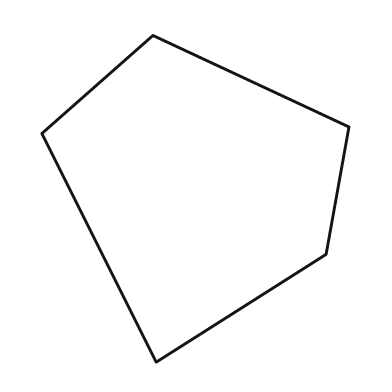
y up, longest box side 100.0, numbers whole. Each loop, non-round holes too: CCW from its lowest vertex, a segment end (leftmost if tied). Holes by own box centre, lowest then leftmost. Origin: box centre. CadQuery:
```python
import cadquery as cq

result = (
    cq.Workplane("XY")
    .moveTo(-12.0, -50.0)
    .lineTo(40.0, -17.0)
    .lineTo(47.0, 22.0)
    .lineTo(-13.0, 50.0)
    .lineTo(-47.0, 20.0)
    .close()
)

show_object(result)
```